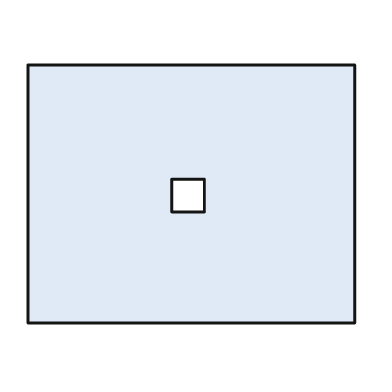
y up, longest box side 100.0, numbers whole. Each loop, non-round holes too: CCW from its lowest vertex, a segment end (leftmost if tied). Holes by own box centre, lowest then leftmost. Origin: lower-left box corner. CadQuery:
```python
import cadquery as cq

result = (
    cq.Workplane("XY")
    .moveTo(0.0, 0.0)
    .lineTo(100.0, 0.0)
    .lineTo(100.0, 79.0)
    .lineTo(0.0, 79.0)
    .close()
    .moveTo(44.0, 34.0)
    .lineTo(54.0, 34.0)
    .lineTo(54.0, 44.0)
    .lineTo(44.0, 44.0)
    .close()
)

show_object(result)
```